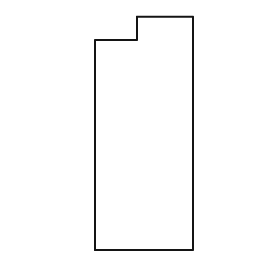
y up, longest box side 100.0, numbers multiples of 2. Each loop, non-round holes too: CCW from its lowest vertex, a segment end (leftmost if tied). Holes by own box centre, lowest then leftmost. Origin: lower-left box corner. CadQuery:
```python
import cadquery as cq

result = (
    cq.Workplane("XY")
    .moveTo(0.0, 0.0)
    .lineTo(42.0, 0.0)
    .lineTo(42.0, 100.0)
    .lineTo(18.0, 100.0)
    .lineTo(18.0, 90.0)
    .lineTo(0.0, 90.0)
    .close()
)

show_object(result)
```